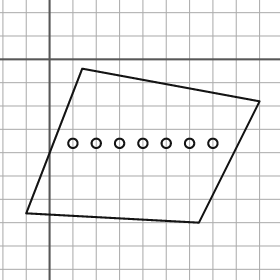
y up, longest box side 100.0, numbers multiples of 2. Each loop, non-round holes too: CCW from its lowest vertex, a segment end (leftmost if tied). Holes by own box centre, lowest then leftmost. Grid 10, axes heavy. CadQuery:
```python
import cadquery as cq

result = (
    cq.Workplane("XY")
    .moveTo(64.0, -70.0)
    .lineTo(90.0, -18.0)
    .lineTo(14.0, -4.0)
    .lineTo(-10.0, -66.0)
    .close()
    .moveTo(10.0, -36.0)
    .circle(2.0)
    .moveTo(20.0, -36.0)
    .circle(2.0)
    .moveTo(30.0, -36.0)
    .circle(2.0)
    .moveTo(40.0, -36.0)
    .circle(2.0)
    .moveTo(50.0, -36.0)
    .circle(2.0)
    .moveTo(60.0, -36.0)
    .circle(2.0)
    .moveTo(70.0, -36.0)
    .circle(2.0)
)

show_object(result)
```